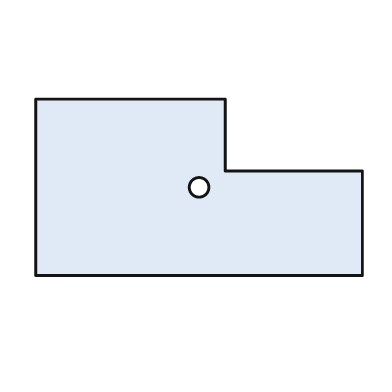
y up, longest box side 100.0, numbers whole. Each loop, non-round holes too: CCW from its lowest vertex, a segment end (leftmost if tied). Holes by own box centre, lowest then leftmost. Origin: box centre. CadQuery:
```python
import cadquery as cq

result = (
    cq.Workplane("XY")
    .moveTo(-50.0, -27.0)
    .lineTo(50.0, -27.0)
    .lineTo(50.0, 5.0)
    .lineTo(8.0, 5.0)
    .lineTo(8.0, 27.0)
    .lineTo(-50.0, 27.0)
    .close()
    .moveTo(0.0, 0.0)
    .circle(3.0)
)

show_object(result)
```